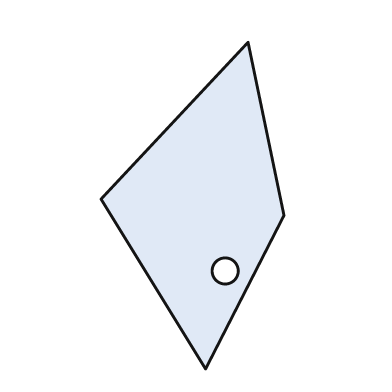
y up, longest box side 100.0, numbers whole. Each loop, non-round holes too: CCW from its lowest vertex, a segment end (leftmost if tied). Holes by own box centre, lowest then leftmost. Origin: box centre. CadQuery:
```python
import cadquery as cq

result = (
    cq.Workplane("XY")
    .moveTo(4.0, -50.0)
    .lineTo(28.0, -3.0)
    .lineTo(17.0, 50.0)
    .lineTo(-28.0, 2.0)
    .close()
    .moveTo(10.0, -20.0)
    .circle(4.0)
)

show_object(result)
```